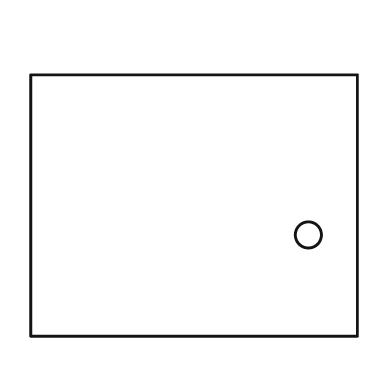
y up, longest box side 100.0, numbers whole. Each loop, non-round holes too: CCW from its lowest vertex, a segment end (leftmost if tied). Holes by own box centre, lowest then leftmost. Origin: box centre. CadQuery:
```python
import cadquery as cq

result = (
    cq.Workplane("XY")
    .moveTo(-50.0, -40.0)
    .lineTo(50.0, -40.0)
    .lineTo(50.0, 40.0)
    .lineTo(-50.0, 40.0)
    .close()
    .moveTo(35.0, -9.0)
    .circle(4.0)
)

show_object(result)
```